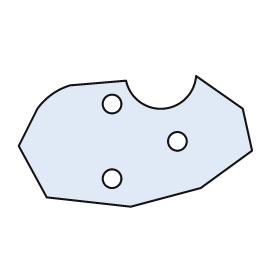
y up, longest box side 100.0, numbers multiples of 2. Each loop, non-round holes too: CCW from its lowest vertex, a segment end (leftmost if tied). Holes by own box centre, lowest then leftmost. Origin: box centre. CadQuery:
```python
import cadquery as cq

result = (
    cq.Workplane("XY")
    .moveTo(-2.0, -28.0)
    .lineTo(28.0, -20.0)
    .lineTo(50.0, -4.0)
    .lineTo(46.0, 14.0)
    .lineTo(26.0, 28.0)
    .threePointArc((12.0, 14.0), (-4.0, 26.0))
    .lineTo(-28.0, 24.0)
    .threePointArc((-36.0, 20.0), (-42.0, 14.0))
    .lineTo(-50.0, -2.0)
    .lineTo(-38.0, -24.0)
    .close()
    .moveTo(-10.0, -16.0)
    .circle(4.0)
    .moveTo(18.0, 0.0)
    .circle(4.0)
    .moveTo(-10.0, 16.0)
    .circle(4.0)
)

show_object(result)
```